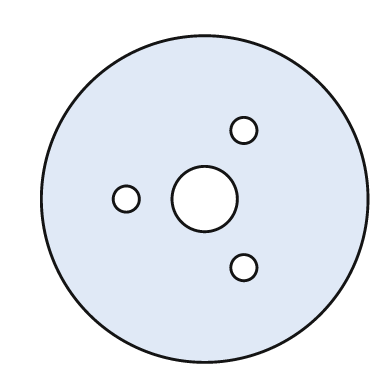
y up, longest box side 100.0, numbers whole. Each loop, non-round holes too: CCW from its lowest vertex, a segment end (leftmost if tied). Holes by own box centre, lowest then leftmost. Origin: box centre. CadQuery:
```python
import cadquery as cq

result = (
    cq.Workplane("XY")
    .moveTo(0.0, 0.0)
    .circle(50.0)
    .moveTo(12.0, -21.0)
    .circle(4.0)
    .moveTo(-24.0, 0.0)
    .circle(4.0)
    .moveTo(0.0, 0.0)
    .circle(10.0)
    .moveTo(12.0, 21.0)
    .circle(4.0)
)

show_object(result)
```